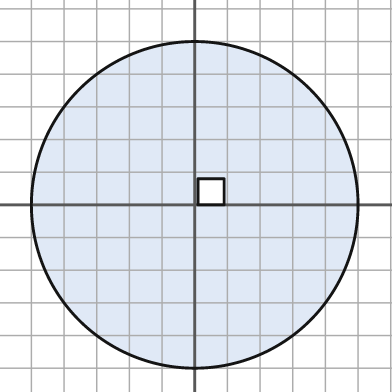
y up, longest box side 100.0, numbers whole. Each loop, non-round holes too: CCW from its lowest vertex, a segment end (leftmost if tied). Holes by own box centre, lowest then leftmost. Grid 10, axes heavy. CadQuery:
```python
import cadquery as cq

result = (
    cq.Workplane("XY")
    .moveTo(0.0, 0.0)
    .circle(50.0)
    .moveTo(1.0, 0.0)
    .lineTo(9.0, 0.0)
    .lineTo(9.0, 8.0)
    .lineTo(1.0, 8.0)
    .close()
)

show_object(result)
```